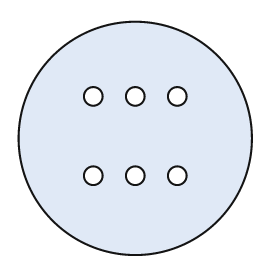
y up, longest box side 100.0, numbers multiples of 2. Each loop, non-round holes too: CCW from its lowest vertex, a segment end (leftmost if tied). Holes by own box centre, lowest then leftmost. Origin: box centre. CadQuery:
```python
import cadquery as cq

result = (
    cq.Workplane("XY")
    .moveTo(0.0, 0.0)
    .circle(50.0)
    .moveTo(-18.0, -16.0)
    .circle(4.0)
    .moveTo(0.0, -16.0)
    .circle(4.0)
    .moveTo(18.0, -16.0)
    .circle(4.0)
    .moveTo(-18.0, 18.0)
    .circle(4.0)
    .moveTo(0.0, 18.0)
    .circle(4.0)
    .moveTo(18.0, 18.0)
    .circle(4.0)
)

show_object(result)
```